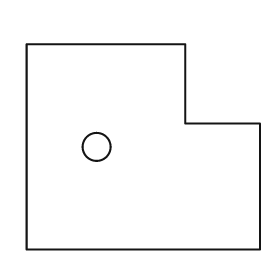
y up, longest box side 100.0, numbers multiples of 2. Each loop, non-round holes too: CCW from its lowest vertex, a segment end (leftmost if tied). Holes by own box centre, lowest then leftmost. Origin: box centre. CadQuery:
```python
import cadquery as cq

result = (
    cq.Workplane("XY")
    .moveTo(-50.0, -44.0)
    .lineTo(50.0, -44.0)
    .lineTo(50.0, 10.0)
    .lineTo(18.0, 10.0)
    .lineTo(18.0, 44.0)
    .lineTo(-50.0, 44.0)
    .close()
    .moveTo(-20.0, 0.0)
    .circle(6.0)
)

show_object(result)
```